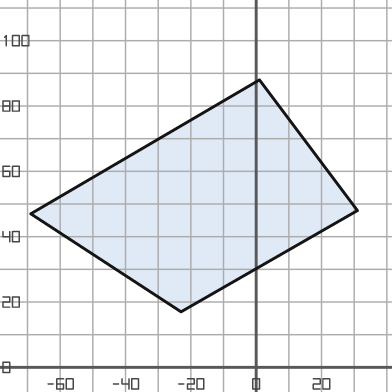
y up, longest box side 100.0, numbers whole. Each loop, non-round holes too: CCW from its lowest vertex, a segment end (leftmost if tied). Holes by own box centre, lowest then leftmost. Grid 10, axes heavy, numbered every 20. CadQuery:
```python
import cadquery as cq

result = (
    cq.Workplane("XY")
    .moveTo(-23.0, 17.0)
    .lineTo(31.0, 48.0)
    .lineTo(1.0, 88.0)
    .lineTo(-69.0, 47.0)
    .close()
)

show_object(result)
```